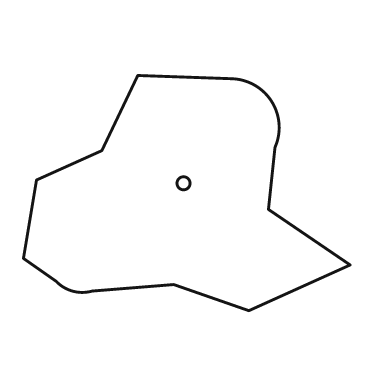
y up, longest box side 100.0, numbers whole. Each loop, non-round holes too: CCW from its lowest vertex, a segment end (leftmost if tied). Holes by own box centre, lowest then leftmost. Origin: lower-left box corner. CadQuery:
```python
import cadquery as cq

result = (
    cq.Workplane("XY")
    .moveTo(69.0, 0.0)
    .lineTo(100.0, 14.0)
    .lineTo(75.0, 31.0)
    .lineTo(77.0, 50.0)
    .threePointArc((76.0, 64.0), (64.0, 71.0))
    .lineTo(35.0, 72.0)
    .lineTo(24.0, 49.0)
    .lineTo(4.0, 40.0)
    .lineTo(0.0, 16.0)
    .lineTo(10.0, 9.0)
    .threePointArc((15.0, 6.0), (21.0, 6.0))
    .lineTo(46.0, 8.0)
    .close()
    .moveTo(49.0, 39.0)
    .circle(2.0)
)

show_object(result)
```